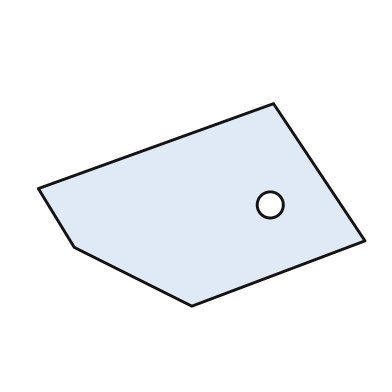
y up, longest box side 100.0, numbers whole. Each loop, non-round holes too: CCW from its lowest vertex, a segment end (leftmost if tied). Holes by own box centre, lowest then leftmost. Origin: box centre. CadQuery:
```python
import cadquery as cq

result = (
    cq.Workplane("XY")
    .moveTo(-3.0, -31.0)
    .lineTo(50.0, -11.0)
    .lineTo(22.0, 31.0)
    .lineTo(-50.0, 5.0)
    .lineTo(-39.0, -13.0)
    .close()
    .moveTo(21.0, 0.0)
    .circle(4.0)
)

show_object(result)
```